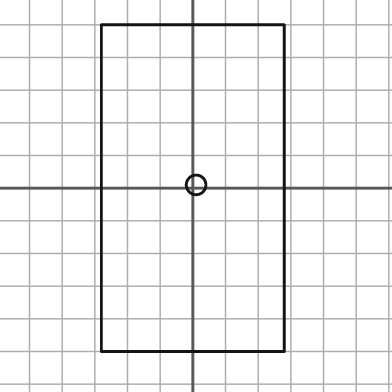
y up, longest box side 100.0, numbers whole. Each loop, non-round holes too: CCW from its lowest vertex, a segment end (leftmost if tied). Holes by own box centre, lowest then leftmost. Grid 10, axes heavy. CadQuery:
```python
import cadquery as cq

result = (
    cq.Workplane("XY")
    .moveTo(-28.0, -50.0)
    .lineTo(28.0, -50.0)
    .lineTo(28.0, 50.0)
    .lineTo(-28.0, 50.0)
    .close()
    .moveTo(1.0, 1.0)
    .circle(3.0)
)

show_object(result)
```